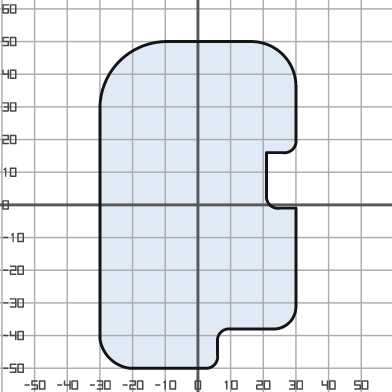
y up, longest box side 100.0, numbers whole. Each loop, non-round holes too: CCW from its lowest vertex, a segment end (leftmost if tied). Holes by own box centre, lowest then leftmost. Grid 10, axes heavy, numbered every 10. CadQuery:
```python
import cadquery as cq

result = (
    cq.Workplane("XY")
    .moveTo(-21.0, -50.0)
    .lineTo(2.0, -50.0)
    .threePointArc((5.0, -49.0), (6.0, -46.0))
    .lineTo(6.0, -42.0)
    .threePointArc((7.0, -39.0), (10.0, -38.0))
    .lineTo(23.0, -38.0)
    .threePointArc((28.0, -36.0), (30.0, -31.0))
    .lineTo(30.0, -1.0)
    .lineTo(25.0, -1.0)
    .threePointArc((22.0, 0.0), (21.0, 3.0))
    .lineTo(21.0, 16.0)
    .lineTo(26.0, 16.0)
    .threePointArc((29.0, 17.0), (30.0, 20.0))
    .lineTo(30.0, 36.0)
    .threePointArc((26.0, 46.0), (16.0, 50.0))
    .lineTo(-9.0, 50.0)
    .threePointArc((-24.0, 44.0), (-30.0, 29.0))
    .lineTo(-30.0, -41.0)
    .threePointArc((-27.0, -47.0), (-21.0, -50.0))
    .close()
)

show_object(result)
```